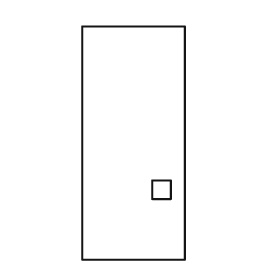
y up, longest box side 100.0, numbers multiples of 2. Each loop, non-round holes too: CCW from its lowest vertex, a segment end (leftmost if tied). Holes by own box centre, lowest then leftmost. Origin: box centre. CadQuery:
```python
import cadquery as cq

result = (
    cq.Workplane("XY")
    .moveTo(-22.0, -50.0)
    .lineTo(22.0, -50.0)
    .lineTo(22.0, 50.0)
    .lineTo(-22.0, 50.0)
    .close()
    .moveTo(8.0, -24.0)
    .lineTo(16.0, -24.0)
    .lineTo(16.0, -16.0)
    .lineTo(8.0, -16.0)
    .close()
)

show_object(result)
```